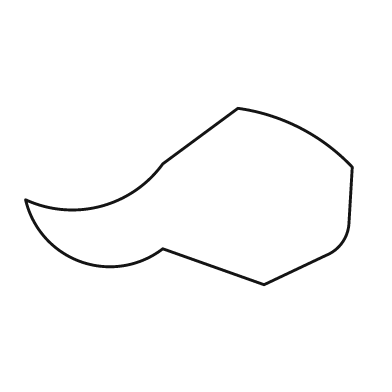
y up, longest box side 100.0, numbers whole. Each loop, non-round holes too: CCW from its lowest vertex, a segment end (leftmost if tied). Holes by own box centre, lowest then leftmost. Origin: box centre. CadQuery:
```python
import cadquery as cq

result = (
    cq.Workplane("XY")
    .moveTo(23.0, -27.0)
    .lineTo(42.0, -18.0)
    .threePointArc((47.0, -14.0), (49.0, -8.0))
    .lineTo(50.0, 9.0)
    .threePointArc((34.0, 21.0), (15.0, 27.0))
    .lineTo(-8.0, 10.0)
    .threePointArc((-27.0, -3.0), (-50.0, -1.0))
    .threePointArc((-33.0, -20.0), (-8.0, -16.0))
    .close()
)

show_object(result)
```